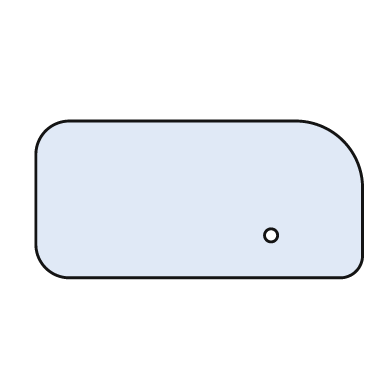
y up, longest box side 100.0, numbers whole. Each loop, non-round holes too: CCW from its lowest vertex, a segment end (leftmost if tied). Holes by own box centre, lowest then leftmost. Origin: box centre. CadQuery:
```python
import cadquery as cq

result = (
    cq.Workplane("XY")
    .moveTo(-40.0, -24.0)
    .lineTo(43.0, -24.0)
    .threePointArc((48.0, -22.0), (50.0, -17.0))
    .lineTo(50.0, 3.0)
    .threePointArc((44.0, 18.0), (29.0, 24.0))
    .lineTo(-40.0, 24.0)
    .threePointArc((-47.0, 21.0), (-50.0, 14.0))
    .lineTo(-50.0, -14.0)
    .threePointArc((-47.0, -21.0), (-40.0, -24.0))
    .close()
    .moveTo(22.0, -11.0)
    .circle(2.0)
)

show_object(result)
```